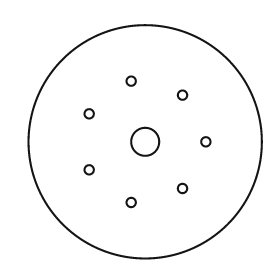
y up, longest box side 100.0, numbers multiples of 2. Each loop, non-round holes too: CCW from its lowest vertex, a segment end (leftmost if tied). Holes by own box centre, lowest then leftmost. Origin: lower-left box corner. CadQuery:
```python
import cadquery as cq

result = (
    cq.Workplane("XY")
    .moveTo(50.0, 50.0)
    .circle(50.0)
    .moveTo(44.0, 24.0)
    .circle(2.0)
    .moveTo(66.0, 30.0)
    .circle(2.0)
    .moveTo(26.0, 38.0)
    .circle(2.0)
    .moveTo(50.0, 50.0)
    .circle(6.0)
    .moveTo(76.0, 50.0)
    .circle(2.0)
    .moveTo(26.0, 62.0)
    .circle(2.0)
    .moveTo(66.0, 70.0)
    .circle(2.0)
    .moveTo(44.0, 76.0)
    .circle(2.0)
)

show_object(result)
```